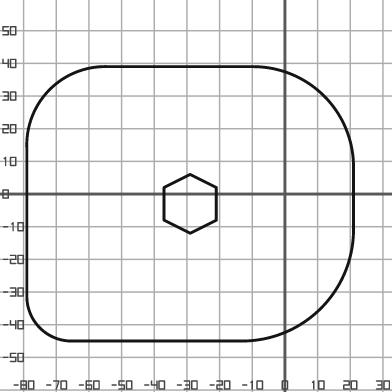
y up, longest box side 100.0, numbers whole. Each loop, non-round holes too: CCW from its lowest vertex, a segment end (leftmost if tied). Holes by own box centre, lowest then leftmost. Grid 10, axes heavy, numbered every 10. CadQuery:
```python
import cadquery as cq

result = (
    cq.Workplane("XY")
    .moveTo(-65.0, -45.0)
    .lineTo(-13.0, -45.0)
    .threePointArc((11.0, -35.0), (21.0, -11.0))
    .lineTo(21.0, 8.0)
    .threePointArc((12.0, 30.0), (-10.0, 39.0))
    .lineTo(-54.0, 39.0)
    .threePointArc((-72.0, 32.0), (-79.0, 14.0))
    .lineTo(-79.0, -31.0)
    .threePointArc((-75.0, -41.0), (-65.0, -45.0))
    .close()
    .moveTo(-29.0, -12.0)
    .lineTo(-21.0, -8.0)
    .lineTo(-21.0, 2.0)
    .lineTo(-29.0, 6.0)
    .lineTo(-37.0, 2.0)
    .lineTo(-37.0, -8.0)
    .close()
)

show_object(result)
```